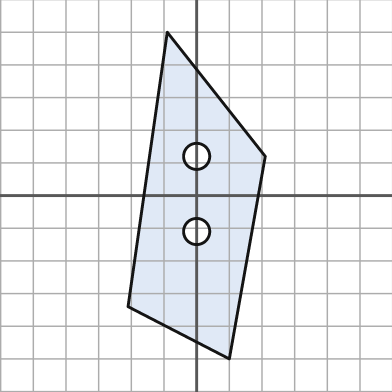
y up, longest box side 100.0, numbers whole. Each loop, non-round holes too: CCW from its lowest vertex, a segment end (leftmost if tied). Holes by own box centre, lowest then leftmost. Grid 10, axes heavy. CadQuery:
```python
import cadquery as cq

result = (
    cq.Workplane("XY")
    .moveTo(10.0, -50.0)
    .lineTo(21.0, 12.0)
    .lineTo(-9.0, 50.0)
    .lineTo(-21.0, -34.0)
    .close()
    .moveTo(0.0, -11.0)
    .circle(4.0)
    .moveTo(0.0, 12.0)
    .circle(4.0)
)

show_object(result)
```